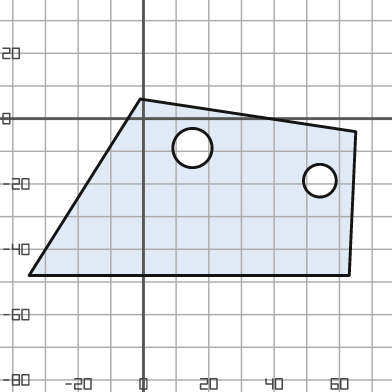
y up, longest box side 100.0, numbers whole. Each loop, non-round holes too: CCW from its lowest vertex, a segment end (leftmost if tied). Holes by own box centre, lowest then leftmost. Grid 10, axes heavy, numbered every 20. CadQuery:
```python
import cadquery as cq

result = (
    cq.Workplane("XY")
    .moveTo(-35.0, -48.0)
    .lineTo(63.0, -48.0)
    .lineTo(65.0, -4.0)
    .lineTo(-1.0, 6.0)
    .close()
    .moveTo(54.0, -19.0)
    .circle(5.0)
    .moveTo(15.0, -9.0)
    .circle(6.0)
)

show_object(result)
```